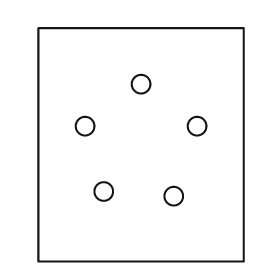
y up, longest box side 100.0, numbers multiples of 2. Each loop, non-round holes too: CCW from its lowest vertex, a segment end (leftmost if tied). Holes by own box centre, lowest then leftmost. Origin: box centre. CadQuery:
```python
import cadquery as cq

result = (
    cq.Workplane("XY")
    .moveTo(-44.0, -50.0)
    .lineTo(44.0, -50.0)
    .lineTo(44.0, 50.0)
    .lineTo(-44.0, 50.0)
    .close()
    .moveTo(14.0, -22.0)
    .circle(4.0)
    .moveTo(-16.0, -20.0)
    .circle(4.0)
    .moveTo(-24.0, 8.0)
    .circle(4.0)
    .moveTo(24.0, 8.0)
    .circle(4.0)
    .moveTo(0.0, 26.0)
    .circle(4.0)
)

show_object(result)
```